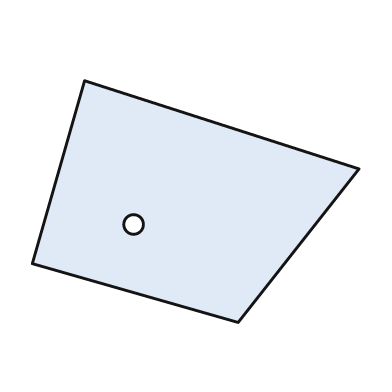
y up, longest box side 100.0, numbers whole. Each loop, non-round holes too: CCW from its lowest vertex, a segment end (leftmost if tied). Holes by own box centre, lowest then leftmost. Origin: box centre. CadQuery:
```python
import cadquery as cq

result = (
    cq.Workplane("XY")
    .moveTo(13.0, -37.0)
    .lineTo(50.0, 10.0)
    .lineTo(-34.0, 37.0)
    .lineTo(-50.0, -19.0)
    .close()
    .moveTo(-19.0, -7.0)
    .circle(3.0)
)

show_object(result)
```